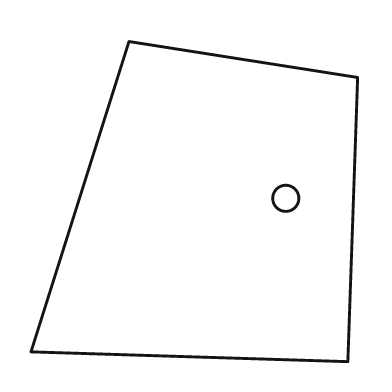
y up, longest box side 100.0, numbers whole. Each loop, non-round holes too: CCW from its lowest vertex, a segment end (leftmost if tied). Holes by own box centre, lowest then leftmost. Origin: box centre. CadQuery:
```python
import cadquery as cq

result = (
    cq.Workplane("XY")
    .moveTo(47.0, -49.0)
    .lineTo(50.0, 38.0)
    .lineTo(-20.0, 49.0)
    .lineTo(-50.0, -46.0)
    .close()
    .moveTo(28.0, 1.0)
    .circle(4.0)
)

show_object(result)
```